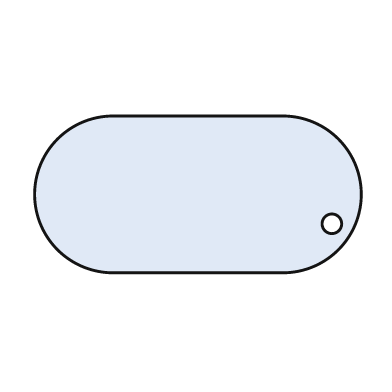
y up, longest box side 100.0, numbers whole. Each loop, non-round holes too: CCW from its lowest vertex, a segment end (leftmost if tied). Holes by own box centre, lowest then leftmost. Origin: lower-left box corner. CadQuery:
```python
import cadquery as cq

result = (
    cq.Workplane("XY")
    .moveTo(24.0, 0.0)
    .lineTo(76.0, 0.0)
    .threePointArc((100.0, 24.0), (76.0, 48.0))
    .lineTo(24.0, 48.0)
    .threePointArc((0.0, 24.0), (24.0, 0.0))
    .close()
    .moveTo(91.0, 15.0)
    .circle(3.0)
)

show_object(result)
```